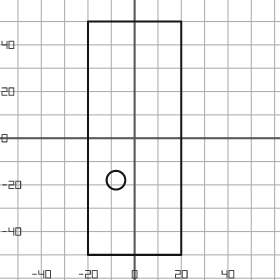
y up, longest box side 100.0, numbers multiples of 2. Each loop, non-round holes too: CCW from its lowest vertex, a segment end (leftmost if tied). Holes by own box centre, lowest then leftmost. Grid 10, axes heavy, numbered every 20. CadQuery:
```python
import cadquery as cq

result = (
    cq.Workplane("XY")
    .moveTo(-20.0, -50.0)
    .lineTo(20.0, -50.0)
    .lineTo(20.0, 50.0)
    .lineTo(-20.0, 50.0)
    .close()
    .moveTo(-8.0, -18.0)
    .circle(4.0)
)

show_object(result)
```